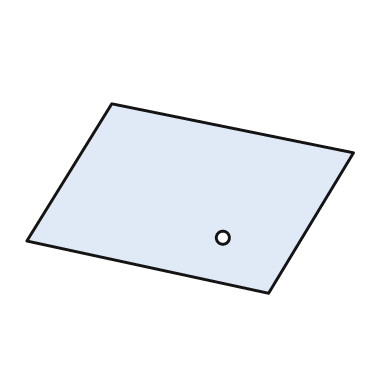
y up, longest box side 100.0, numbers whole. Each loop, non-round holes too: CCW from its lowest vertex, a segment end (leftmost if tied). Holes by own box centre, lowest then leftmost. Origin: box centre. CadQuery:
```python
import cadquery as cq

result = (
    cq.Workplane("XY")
    .moveTo(24.0, -29.0)
    .lineTo(50.0, 14.0)
    .lineTo(-24.0, 29.0)
    .lineTo(-50.0, -13.0)
    .close()
    .moveTo(10.0, -12.0)
    .circle(2.0)
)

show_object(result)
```